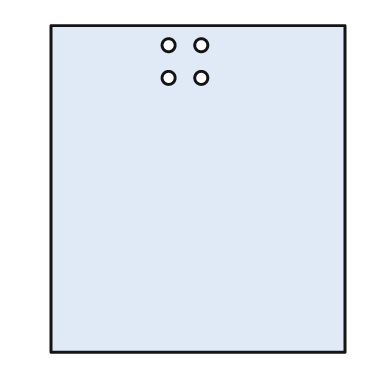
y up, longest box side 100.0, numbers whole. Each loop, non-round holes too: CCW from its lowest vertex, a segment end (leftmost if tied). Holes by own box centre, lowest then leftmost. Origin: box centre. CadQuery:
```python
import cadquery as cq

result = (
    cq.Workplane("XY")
    .moveTo(-45.0, -50.0)
    .lineTo(45.0, -50.0)
    .lineTo(45.0, 50.0)
    .lineTo(-45.0, 50.0)
    .close()
    .moveTo(-9.0, 34.0)
    .circle(2.0)
    .moveTo(1.0, 34.0)
    .circle(2.0)
    .moveTo(-9.0, 44.0)
    .circle(2.0)
    .moveTo(1.0, 44.0)
    .circle(2.0)
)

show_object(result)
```